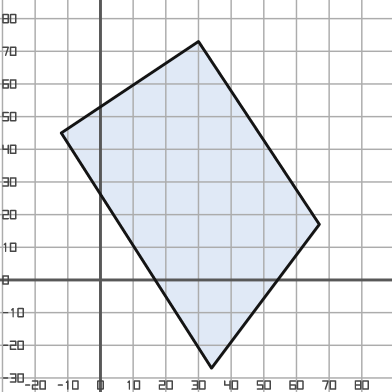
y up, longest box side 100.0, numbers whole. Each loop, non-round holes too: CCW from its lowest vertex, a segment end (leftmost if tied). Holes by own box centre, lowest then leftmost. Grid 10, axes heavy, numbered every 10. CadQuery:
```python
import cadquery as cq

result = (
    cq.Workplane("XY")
    .moveTo(34.0, -27.0)
    .lineTo(67.0, 17.0)
    .lineTo(30.0, 73.0)
    .lineTo(-12.0, 45.0)
    .close()
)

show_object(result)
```